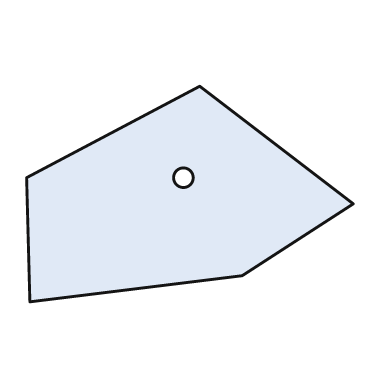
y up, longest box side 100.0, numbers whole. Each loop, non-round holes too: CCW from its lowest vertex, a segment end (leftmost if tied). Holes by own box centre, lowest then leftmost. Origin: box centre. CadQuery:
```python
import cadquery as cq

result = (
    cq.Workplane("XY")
    .moveTo(-49.0, -33.0)
    .lineTo(16.0, -25.0)
    .lineTo(50.0, -3.0)
    .lineTo(3.0, 33.0)
    .lineTo(-50.0, 5.0)
    .close()
    .moveTo(-2.0, 5.0)
    .circle(3.0)
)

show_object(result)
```